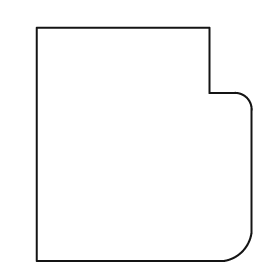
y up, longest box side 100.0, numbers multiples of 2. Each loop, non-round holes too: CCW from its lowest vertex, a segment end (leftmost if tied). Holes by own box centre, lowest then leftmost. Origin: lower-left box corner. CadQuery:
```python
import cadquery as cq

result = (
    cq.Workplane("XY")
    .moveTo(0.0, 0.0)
    .lineTo(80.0, 0.0)
    .threePointArc((88.0, 4.0), (92.0, 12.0))
    .lineTo(92.0, 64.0)
    .threePointArc((90.0, 70.0), (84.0, 72.0))
    .lineTo(74.0, 72.0)
    .lineTo(74.0, 100.0)
    .lineTo(0.0, 100.0)
    .close()
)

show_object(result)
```